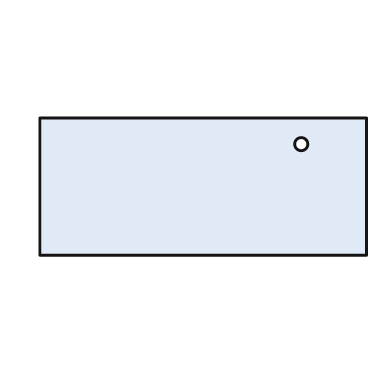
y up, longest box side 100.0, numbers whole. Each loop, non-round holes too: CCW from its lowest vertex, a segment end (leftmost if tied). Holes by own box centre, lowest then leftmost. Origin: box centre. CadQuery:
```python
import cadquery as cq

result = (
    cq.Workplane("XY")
    .moveTo(-50.0, -21.0)
    .lineTo(50.0, -21.0)
    .lineTo(50.0, 21.0)
    .lineTo(-50.0, 21.0)
    .close()
    .moveTo(30.0, 13.0)
    .circle(2.0)
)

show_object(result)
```